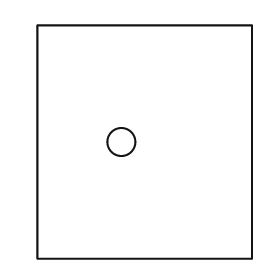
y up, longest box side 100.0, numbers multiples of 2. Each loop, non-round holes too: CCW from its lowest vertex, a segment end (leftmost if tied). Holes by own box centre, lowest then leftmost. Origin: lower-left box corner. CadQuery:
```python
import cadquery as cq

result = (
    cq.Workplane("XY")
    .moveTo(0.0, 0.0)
    .lineTo(92.0, 0.0)
    .lineTo(92.0, 100.0)
    .lineTo(0.0, 100.0)
    .close()
    .moveTo(36.0, 50.0)
    .circle(6.0)
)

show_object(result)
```